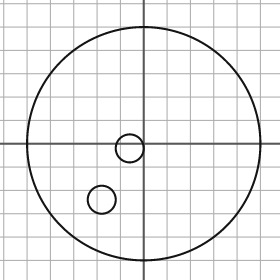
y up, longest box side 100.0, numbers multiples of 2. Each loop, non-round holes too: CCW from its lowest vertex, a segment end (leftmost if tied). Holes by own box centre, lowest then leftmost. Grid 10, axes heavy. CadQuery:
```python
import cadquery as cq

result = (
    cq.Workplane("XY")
    .moveTo(0.0, 0.0)
    .circle(50.0)
    .moveTo(-18.0, -24.0)
    .circle(6.0)
    .moveTo(-6.0, -2.0)
    .circle(6.0)
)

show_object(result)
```